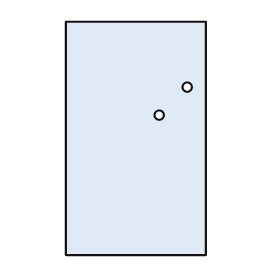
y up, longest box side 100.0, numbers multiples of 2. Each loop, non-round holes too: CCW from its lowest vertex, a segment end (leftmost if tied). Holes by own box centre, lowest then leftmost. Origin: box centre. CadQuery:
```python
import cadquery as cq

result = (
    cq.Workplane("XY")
    .moveTo(-30.0, -50.0)
    .lineTo(30.0, -50.0)
    .lineTo(30.0, 50.0)
    .lineTo(-30.0, 50.0)
    .close()
    .moveTo(10.0, 10.0)
    .circle(2.0)
    .moveTo(22.0, 22.0)
    .circle(2.0)
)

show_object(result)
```